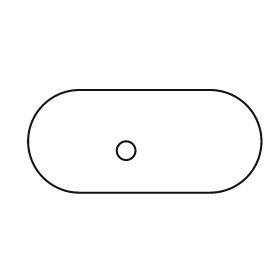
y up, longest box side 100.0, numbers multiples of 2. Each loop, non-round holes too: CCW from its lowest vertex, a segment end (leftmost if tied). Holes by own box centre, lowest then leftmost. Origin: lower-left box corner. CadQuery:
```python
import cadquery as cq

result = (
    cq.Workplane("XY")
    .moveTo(22.0, 0.0)
    .lineTo(78.0, 0.0)
    .threePointArc((100.0, 22.0), (78.0, 44.0))
    .lineTo(22.0, 44.0)
    .threePointArc((0.0, 22.0), (22.0, 0.0))
    .close()
    .moveTo(42.0, 18.0)
    .circle(4.0)
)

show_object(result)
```